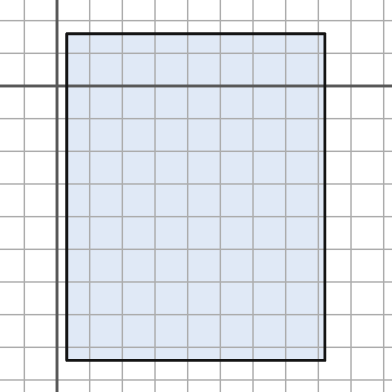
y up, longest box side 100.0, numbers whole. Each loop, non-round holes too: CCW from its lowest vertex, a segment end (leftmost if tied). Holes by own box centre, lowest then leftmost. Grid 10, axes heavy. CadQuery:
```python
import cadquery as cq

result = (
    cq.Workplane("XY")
    .moveTo(3.0, -84.0)
    .lineTo(82.0, -84.0)
    .lineTo(82.0, 16.0)
    .lineTo(3.0, 16.0)
    .close()
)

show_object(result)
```